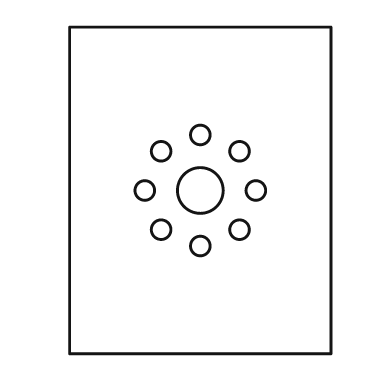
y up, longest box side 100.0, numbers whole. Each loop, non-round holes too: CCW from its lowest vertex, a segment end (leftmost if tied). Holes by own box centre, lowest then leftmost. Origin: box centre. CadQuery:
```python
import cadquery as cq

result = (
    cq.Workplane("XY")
    .moveTo(-40.0, -50.0)
    .lineTo(40.0, -50.0)
    .lineTo(40.0, 50.0)
    .lineTo(-40.0, 50.0)
    .close()
    .moveTo(0.0, -17.0)
    .circle(3.0)
    .moveTo(-12.0, -12.0)
    .circle(3.0)
    .moveTo(12.0, -12.0)
    .circle(3.0)
    .moveTo(-17.0, 0.0)
    .circle(3.0)
    .moveTo(0.0, 0.0)
    .circle(7.0)
    .moveTo(17.0, 0.0)
    .circle(3.0)
    .moveTo(-12.0, 12.0)
    .circle(3.0)
    .moveTo(12.0, 12.0)
    .circle(3.0)
    .moveTo(0.0, 17.0)
    .circle(3.0)
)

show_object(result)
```